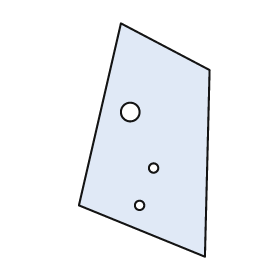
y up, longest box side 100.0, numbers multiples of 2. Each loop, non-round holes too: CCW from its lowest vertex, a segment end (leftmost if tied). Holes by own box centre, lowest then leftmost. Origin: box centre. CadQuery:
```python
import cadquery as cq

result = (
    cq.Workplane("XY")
    .moveTo(26.0, -50.0)
    .lineTo(28.0, 30.0)
    .lineTo(-10.0, 50.0)
    .lineTo(-28.0, -28.0)
    .close()
    .moveTo(-2.0, -28.0)
    .circle(2.0)
    .moveTo(4.0, -12.0)
    .circle(2.0)
    .moveTo(-6.0, 12.0)
    .circle(4.0)
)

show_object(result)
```